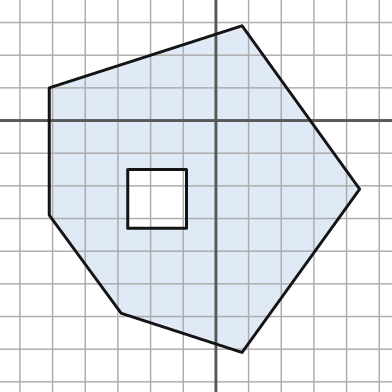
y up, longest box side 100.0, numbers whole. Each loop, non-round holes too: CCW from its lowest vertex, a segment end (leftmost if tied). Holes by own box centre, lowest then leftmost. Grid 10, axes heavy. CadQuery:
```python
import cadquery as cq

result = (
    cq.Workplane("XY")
    .moveTo(8.0, -71.0)
    .lineTo(44.0, -21.0)
    .lineTo(8.0, 29.0)
    .lineTo(-51.0, 10.0)
    .lineTo(-51.0, -29.0)
    .lineTo(-29.0, -59.0)
    .close()
    .moveTo(-27.0, -33.0)
    .lineTo(-9.0, -33.0)
    .lineTo(-9.0, -15.0)
    .lineTo(-27.0, -15.0)
    .close()
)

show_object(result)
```